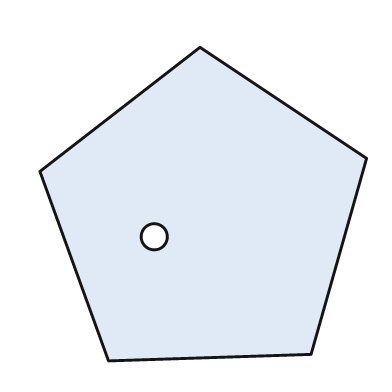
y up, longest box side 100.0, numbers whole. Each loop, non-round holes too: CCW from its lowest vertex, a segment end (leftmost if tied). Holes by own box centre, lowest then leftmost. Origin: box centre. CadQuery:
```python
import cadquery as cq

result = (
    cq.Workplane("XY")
    .moveTo(-29.0, -48.0)
    .lineTo(33.0, -46.0)
    .lineTo(50.0, 14.0)
    .lineTo(-1.0, 48.0)
    .lineTo(-50.0, 10.0)
    .close()
    .moveTo(-15.0, -10.0)
    .circle(4.0)
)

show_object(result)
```